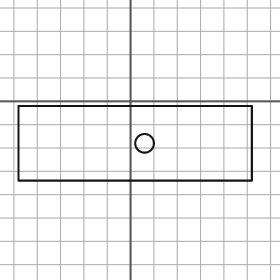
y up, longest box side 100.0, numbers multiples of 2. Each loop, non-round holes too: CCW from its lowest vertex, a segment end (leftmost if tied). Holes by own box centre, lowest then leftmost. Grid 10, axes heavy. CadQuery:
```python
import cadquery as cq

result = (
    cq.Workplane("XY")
    .moveTo(-48.0, -34.0)
    .lineTo(52.0, -34.0)
    .lineTo(52.0, -2.0)
    .lineTo(-48.0, -2.0)
    .close()
    .moveTo(6.0, -18.0)
    .circle(4.0)
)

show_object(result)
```